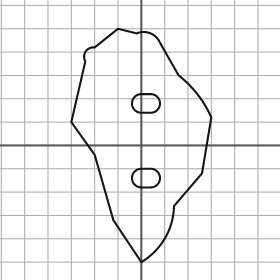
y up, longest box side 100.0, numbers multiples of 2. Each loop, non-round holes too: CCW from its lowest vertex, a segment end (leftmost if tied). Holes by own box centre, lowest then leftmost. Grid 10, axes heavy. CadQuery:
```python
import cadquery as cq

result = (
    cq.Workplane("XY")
    .moveTo(0.0, -50.0)
    .threePointArc((10.0, -40.0), (14.0, -26.0))
    .lineTo(26.0, -12.0)
    .lineTo(30.0, 12.0)
    .threePointArc((24.0, 22.0), (16.0, 30.0))
    .lineTo(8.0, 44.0)
    .threePointArc((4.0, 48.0), (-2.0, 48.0))
    .lineTo(-10.0, 50.0)
    .lineTo(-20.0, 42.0)
    .threePointArc((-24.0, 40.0), (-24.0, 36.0))
    .lineTo(-30.0, 10.0)
    .lineTo(-20.0, -4.0)
    .lineTo(-12.0, -32.0)
    .close()
    .moveTo(0.0, -18.0)
    .lineTo(4.0, -18.0)
    .threePointArc((8.0, -14.0), (4.0, -10.0))
    .lineTo(0.0, -10.0)
    .threePointArc((-4.0, -14.0), (0.0, -18.0))
    .close()
    .moveTo(0.0, 14.0)
    .lineTo(4.0, 14.0)
    .threePointArc((8.0, 18.0), (4.0, 22.0))
    .lineTo(0.0, 22.0)
    .threePointArc((-4.0, 18.0), (0.0, 14.0))
    .close()
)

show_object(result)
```